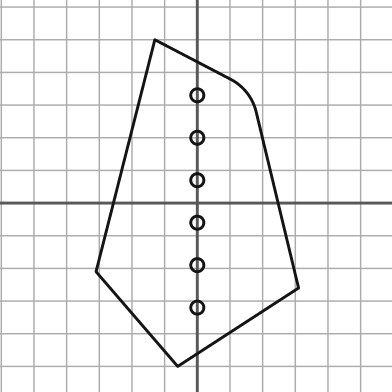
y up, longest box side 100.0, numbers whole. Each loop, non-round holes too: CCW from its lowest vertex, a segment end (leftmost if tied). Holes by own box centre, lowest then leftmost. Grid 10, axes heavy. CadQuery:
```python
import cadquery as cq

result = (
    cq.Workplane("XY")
    .moveTo(-6.0, -50.0)
    .lineTo(31.0, -26.0)
    .lineTo(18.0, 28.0)
    .threePointArc((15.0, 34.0), (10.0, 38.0))
    .lineTo(-13.0, 50.0)
    .lineTo(-31.0, -21.0)
    .close()
    .moveTo(0.0, -32.0)
    .circle(2.0)
    .moveTo(0.0, -19.0)
    .circle(2.0)
    .moveTo(0.0, -6.0)
    .circle(2.0)
    .moveTo(0.0, 7.0)
    .circle(2.0)
    .moveTo(0.0, 20.0)
    .circle(2.0)
    .moveTo(0.0, 33.0)
    .circle(2.0)
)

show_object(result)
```